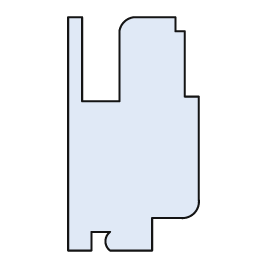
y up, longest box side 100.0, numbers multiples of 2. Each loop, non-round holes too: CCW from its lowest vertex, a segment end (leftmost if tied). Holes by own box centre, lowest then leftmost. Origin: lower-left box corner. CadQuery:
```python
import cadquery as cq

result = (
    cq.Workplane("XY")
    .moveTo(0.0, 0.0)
    .lineTo(10.0, 0.0)
    .lineTo(10.0, 8.0)
    .lineTo(18.0, 8.0)
    .threePointArc((16.0, 4.0), (18.0, 0.0))
    .lineTo(36.0, 0.0)
    .lineTo(36.0, 14.0)
    .lineTo(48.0, 14.0)
    .threePointArc((54.0, 16.0), (56.0, 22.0))
    .lineTo(56.0, 66.0)
    .lineTo(50.0, 66.0)
    .lineTo(50.0, 94.0)
    .lineTo(46.0, 94.0)
    .lineTo(46.0, 100.0)
    .lineTo(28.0, 100.0)
    .threePointArc((24.0, 98.0), (22.0, 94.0))
    .lineTo(22.0, 64.0)
    .lineTo(6.0, 64.0)
    .lineTo(6.0, 100.0)
    .lineTo(0.0, 100.0)
    .close()
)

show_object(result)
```